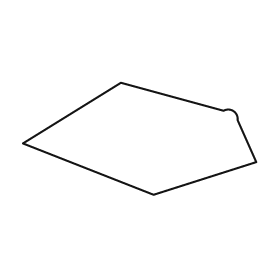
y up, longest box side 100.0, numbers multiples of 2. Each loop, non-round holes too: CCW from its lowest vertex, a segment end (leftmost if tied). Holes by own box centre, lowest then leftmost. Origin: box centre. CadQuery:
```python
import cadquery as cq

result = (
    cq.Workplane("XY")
    .moveTo(6.0, -24.0)
    .lineTo(50.0, -10.0)
    .lineTo(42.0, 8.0)
    .threePointArc((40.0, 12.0), (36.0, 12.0))
    .lineTo(-8.0, 24.0)
    .lineTo(-50.0, -2.0)
    .close()
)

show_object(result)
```